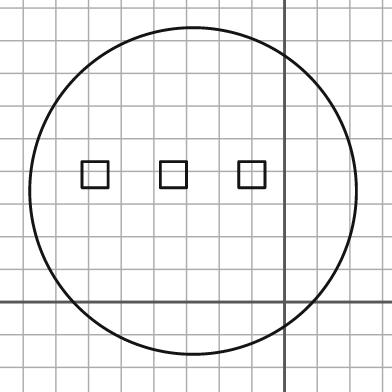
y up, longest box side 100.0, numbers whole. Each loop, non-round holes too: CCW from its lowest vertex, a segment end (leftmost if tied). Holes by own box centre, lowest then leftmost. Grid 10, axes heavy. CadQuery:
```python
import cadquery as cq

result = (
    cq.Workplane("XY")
    .moveTo(-28.0, 34.0)
    .circle(50.0)
    .moveTo(-62.0, 35.0)
    .lineTo(-54.0, 35.0)
    .lineTo(-54.0, 43.0)
    .lineTo(-62.0, 43.0)
    .close()
    .moveTo(-38.0, 35.0)
    .lineTo(-30.0, 35.0)
    .lineTo(-30.0, 43.0)
    .lineTo(-38.0, 43.0)
    .close()
    .moveTo(-14.0, 35.0)
    .lineTo(-6.0, 35.0)
    .lineTo(-6.0, 43.0)
    .lineTo(-14.0, 43.0)
    .close()
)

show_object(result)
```